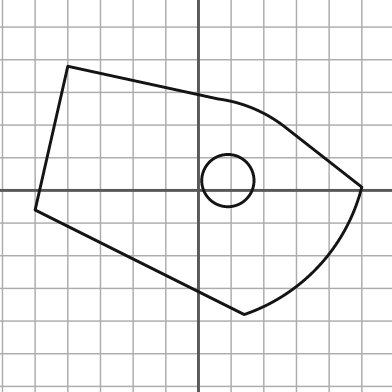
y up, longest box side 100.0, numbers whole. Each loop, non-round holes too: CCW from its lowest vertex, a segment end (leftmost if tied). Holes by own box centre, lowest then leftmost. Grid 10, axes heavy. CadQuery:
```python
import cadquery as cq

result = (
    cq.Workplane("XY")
    .moveTo(14.0, -38.0)
    .threePointArc((37.0, -23.0), (50.0, 1.0))
    .lineTo(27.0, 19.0)
    .threePointArc((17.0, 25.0), (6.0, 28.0))
    .lineTo(-40.0, 38.0)
    .lineTo(-50.0, -6.0)
    .close()
    .moveTo(9.0, 3.0)
    .circle(8.0)
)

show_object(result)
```